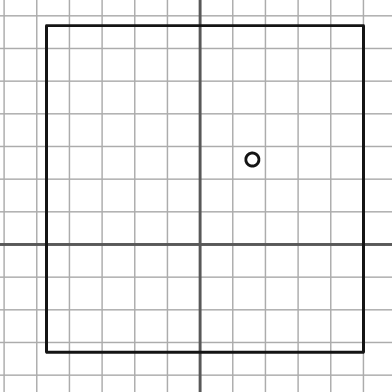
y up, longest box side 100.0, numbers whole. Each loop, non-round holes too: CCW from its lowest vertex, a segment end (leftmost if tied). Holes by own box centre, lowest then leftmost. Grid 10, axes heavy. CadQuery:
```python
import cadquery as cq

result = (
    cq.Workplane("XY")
    .moveTo(-47.0, -33.0)
    .lineTo(50.0, -33.0)
    .lineTo(50.0, 67.0)
    .lineTo(-47.0, 67.0)
    .close()
    .moveTo(16.0, 26.0)
    .circle(2.0)
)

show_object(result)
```